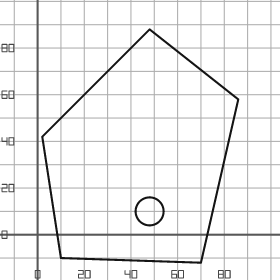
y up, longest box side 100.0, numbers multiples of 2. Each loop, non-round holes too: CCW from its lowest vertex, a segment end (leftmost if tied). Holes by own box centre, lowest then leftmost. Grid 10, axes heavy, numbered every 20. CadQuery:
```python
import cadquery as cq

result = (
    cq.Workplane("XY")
    .moveTo(70.0, -12.0)
    .lineTo(86.0, 58.0)
    .lineTo(48.0, 88.0)
    .lineTo(2.0, 42.0)
    .lineTo(10.0, -10.0)
    .close()
    .moveTo(48.0, 10.0)
    .circle(6.0)
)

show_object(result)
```